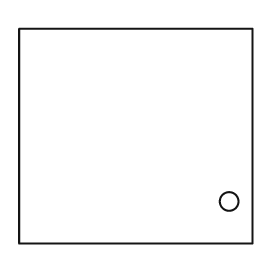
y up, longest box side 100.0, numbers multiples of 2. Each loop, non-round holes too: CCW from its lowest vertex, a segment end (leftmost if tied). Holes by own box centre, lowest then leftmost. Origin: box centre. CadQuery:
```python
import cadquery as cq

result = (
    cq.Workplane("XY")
    .moveTo(-50.0, -46.0)
    .lineTo(50.0, -46.0)
    .lineTo(50.0, 46.0)
    .lineTo(-50.0, 46.0)
    .close()
    .moveTo(40.0, -28.0)
    .circle(4.0)
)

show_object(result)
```